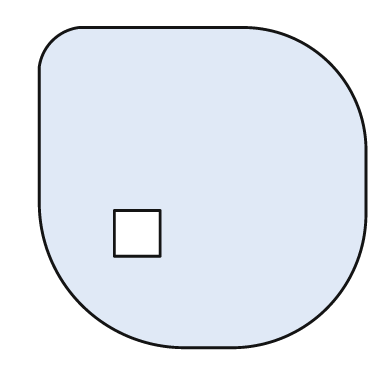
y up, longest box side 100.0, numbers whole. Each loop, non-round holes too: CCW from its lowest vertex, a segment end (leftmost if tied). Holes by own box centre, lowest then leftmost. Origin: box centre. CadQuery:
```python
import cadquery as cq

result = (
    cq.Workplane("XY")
    .moveTo(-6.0, -49.0)
    .lineTo(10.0, -49.0)
    .threePointArc((38.0, -37.0), (50.0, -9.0))
    .lineTo(50.0, 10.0)
    .threePointArc((39.0, 38.0), (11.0, 49.0))
    .lineTo(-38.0, 49.0)
    .threePointArc((-46.0, 45.0), (-50.0, 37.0))
    .lineTo(-50.0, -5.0)
    .threePointArc((-37.0, -36.0), (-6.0, -49.0))
    .close()
    .moveTo(-27.0, -21.0)
    .lineTo(-13.0, -21.0)
    .lineTo(-13.0, -7.0)
    .lineTo(-27.0, -7.0)
    .close()
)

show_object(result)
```